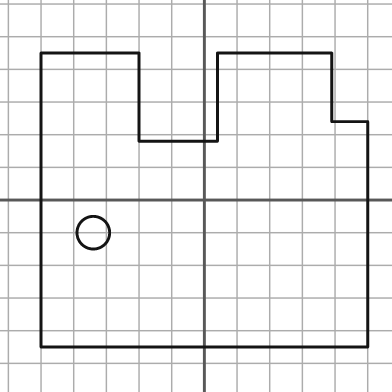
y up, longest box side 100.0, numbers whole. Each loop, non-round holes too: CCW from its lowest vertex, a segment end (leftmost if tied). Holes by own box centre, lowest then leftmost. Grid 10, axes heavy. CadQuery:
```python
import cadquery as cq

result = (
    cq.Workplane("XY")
    .moveTo(-50.0, -45.0)
    .lineTo(50.0, -45.0)
    .lineTo(50.0, 24.0)
    .lineTo(39.0, 24.0)
    .lineTo(39.0, 45.0)
    .lineTo(4.0, 45.0)
    .lineTo(4.0, 18.0)
    .lineTo(-20.0, 18.0)
    .lineTo(-20.0, 45.0)
    .lineTo(-50.0, 45.0)
    .close()
    .moveTo(-34.0, -10.0)
    .circle(5.0)
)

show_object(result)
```